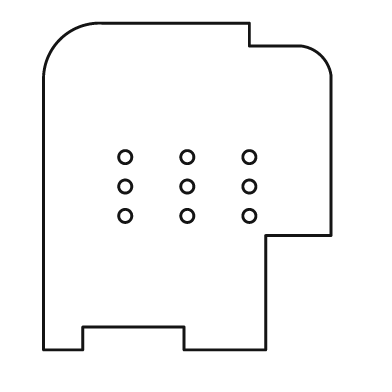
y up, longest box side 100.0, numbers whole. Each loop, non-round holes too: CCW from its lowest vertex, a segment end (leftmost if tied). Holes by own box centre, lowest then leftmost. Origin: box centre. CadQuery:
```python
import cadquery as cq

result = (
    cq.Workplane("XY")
    .moveTo(-44.0, -50.0)
    .lineTo(-32.0, -50.0)
    .lineTo(-32.0, -43.0)
    .lineTo(-1.0, -43.0)
    .lineTo(-1.0, -50.0)
    .lineTo(24.0, -50.0)
    .lineTo(24.0, -15.0)
    .lineTo(44.0, -15.0)
    .lineTo(44.0, 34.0)
    .threePointArc((41.0, 40.0), (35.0, 43.0))
    .lineTo(19.0, 43.0)
    .lineTo(19.0, 50.0)
    .lineTo(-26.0, 50.0)
    .threePointArc((-39.0, 45.0), (-44.0, 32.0))
    .close()
    .moveTo(-19.0, -9.0)
    .circle(2.0)
    .moveTo(0.0, -9.0)
    .circle(2.0)
    .moveTo(19.0, -9.0)
    .circle(2.0)
    .moveTo(-19.0, 0.0)
    .circle(2.0)
    .moveTo(0.0, 0.0)
    .circle(2.0)
    .moveTo(19.0, 0.0)
    .circle(2.0)
    .moveTo(-19.0, 9.0)
    .circle(2.0)
    .moveTo(0.0, 9.0)
    .circle(2.0)
    .moveTo(19.0, 9.0)
    .circle(2.0)
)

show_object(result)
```